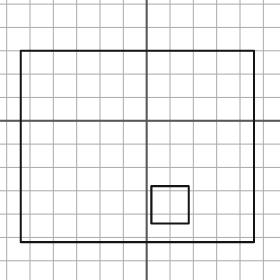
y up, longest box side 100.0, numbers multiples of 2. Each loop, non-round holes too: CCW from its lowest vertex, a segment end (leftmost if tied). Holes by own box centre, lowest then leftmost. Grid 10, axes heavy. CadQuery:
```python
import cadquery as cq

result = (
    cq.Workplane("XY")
    .moveTo(-54.0, -52.0)
    .lineTo(46.0, -52.0)
    .lineTo(46.0, 30.0)
    .lineTo(-54.0, 30.0)
    .close()
    .moveTo(2.0, -44.0)
    .lineTo(18.0, -44.0)
    .lineTo(18.0, -28.0)
    .lineTo(2.0, -28.0)
    .close()
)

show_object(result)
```